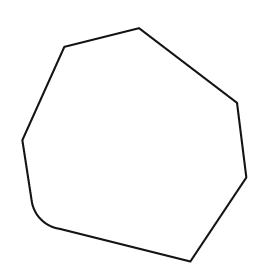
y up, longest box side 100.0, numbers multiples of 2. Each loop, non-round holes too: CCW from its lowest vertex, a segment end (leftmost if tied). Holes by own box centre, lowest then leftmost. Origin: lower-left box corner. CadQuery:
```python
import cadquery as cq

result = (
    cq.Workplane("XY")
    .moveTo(72.0, 0.0)
    .lineTo(96.0, 36.0)
    .lineTo(92.0, 68.0)
    .lineTo(50.0, 100.0)
    .lineTo(18.0, 92.0)
    .lineTo(0.0, 52.0)
    .lineTo(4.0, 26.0)
    .threePointArc((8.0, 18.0), (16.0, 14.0))
    .close()
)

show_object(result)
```